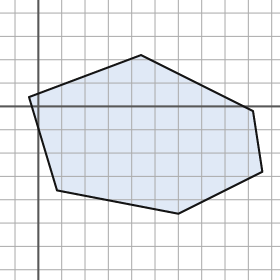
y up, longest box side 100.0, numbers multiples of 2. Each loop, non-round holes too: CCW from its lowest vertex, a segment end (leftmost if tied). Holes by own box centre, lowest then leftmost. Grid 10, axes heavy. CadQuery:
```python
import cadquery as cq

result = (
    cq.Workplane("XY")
    .moveTo(60.0, -46.0)
    .lineTo(96.0, -28.0)
    .lineTo(92.0, -2.0)
    .lineTo(44.0, 22.0)
    .lineTo(-4.0, 4.0)
    .lineTo(8.0, -36.0)
    .close()
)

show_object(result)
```